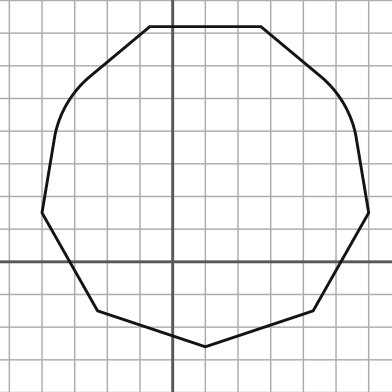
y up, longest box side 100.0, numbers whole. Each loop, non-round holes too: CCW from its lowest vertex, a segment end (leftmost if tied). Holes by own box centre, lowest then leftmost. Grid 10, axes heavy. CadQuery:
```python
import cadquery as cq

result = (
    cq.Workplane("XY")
    .moveTo(10.0, -26.0)
    .lineTo(43.0, -15.0)
    .lineTo(60.0, 15.0)
    .lineTo(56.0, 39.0)
    .threePointArc((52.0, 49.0), (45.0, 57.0))
    .lineTo(27.0, 72.0)
    .lineTo(-7.0, 72.0)
    .lineTo(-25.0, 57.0)
    .threePointArc((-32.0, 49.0), (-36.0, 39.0))
    .lineTo(-40.0, 15.0)
    .lineTo(-23.0, -15.0)
    .close()
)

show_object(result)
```